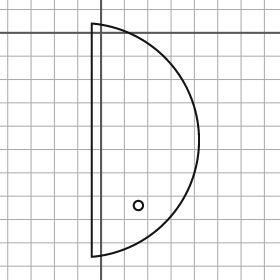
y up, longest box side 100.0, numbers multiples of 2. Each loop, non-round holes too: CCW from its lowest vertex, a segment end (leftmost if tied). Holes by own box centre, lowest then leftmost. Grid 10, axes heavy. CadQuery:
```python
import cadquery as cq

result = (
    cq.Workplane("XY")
    .moveTo(-4.0, -96.0)
    .threePointArc((42.0, -46.0), (-4.0, 4.0))
    .close()
    .moveTo(16.0, -74.0)
    .circle(2.0)
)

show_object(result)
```